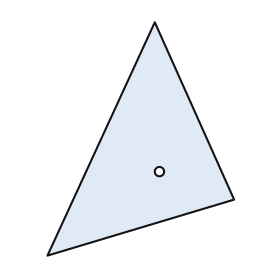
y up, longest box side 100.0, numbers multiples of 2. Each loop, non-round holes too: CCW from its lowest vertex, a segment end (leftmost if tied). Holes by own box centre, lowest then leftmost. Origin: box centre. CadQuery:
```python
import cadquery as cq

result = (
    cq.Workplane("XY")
    .moveTo(-40.0, -50.0)
    .lineTo(40.0, -26.0)
    .lineTo(6.0, 50.0)
    .close()
    .moveTo(8.0, -14.0)
    .circle(2.0)
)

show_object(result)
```